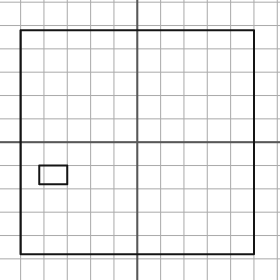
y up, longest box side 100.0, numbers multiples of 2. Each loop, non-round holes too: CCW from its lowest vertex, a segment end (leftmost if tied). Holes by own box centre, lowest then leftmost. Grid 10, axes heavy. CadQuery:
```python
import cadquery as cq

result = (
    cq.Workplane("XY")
    .moveTo(-50.0, -48.0)
    .lineTo(50.0, -48.0)
    .lineTo(50.0, 48.0)
    .lineTo(-50.0, 48.0)
    .close()
    .moveTo(-42.0, -18.0)
    .lineTo(-30.0, -18.0)
    .lineTo(-30.0, -10.0)
    .lineTo(-42.0, -10.0)
    .close()
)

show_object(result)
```